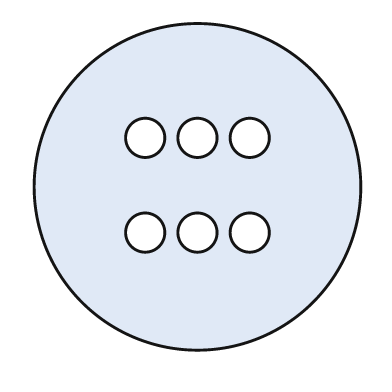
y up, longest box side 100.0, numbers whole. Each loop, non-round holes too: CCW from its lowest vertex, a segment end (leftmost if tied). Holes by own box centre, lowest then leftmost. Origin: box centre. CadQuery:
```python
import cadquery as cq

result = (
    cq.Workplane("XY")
    .moveTo(0.0, 0.0)
    .circle(50.0)
    .moveTo(-16.0, -14.0)
    .circle(6.0)
    .moveTo(0.0, -14.0)
    .circle(6.0)
    .moveTo(16.0, -14.0)
    .circle(6.0)
    .moveTo(-16.0, 15.0)
    .circle(6.0)
    .moveTo(0.0, 15.0)
    .circle(6.0)
    .moveTo(16.0, 15.0)
    .circle(6.0)
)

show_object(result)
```